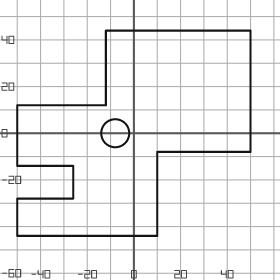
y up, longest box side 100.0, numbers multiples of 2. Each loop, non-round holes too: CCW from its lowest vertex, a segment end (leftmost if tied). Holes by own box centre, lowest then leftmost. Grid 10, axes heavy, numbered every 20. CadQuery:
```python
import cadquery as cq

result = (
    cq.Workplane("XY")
    .moveTo(-50.0, -44.0)
    .lineTo(10.0, -44.0)
    .lineTo(10.0, -8.0)
    .lineTo(50.0, -8.0)
    .lineTo(50.0, 44.0)
    .lineTo(-12.0, 44.0)
    .lineTo(-12.0, 12.0)
    .lineTo(-50.0, 12.0)
    .lineTo(-50.0, -14.0)
    .lineTo(-26.0, -14.0)
    .lineTo(-26.0, -28.0)
    .lineTo(-50.0, -28.0)
    .close()
    .moveTo(-8.0, 0.0)
    .circle(6.0)
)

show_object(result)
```